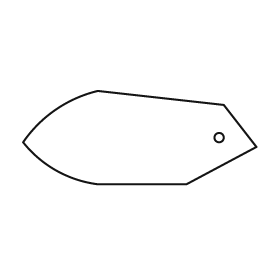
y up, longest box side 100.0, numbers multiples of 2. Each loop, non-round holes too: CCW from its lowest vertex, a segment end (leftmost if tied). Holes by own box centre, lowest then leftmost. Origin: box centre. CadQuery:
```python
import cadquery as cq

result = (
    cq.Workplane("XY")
    .moveTo(-18.0, -20.0)
    .lineTo(20.0, -20.0)
    .lineTo(50.0, -4.0)
    .lineTo(36.0, 14.0)
    .lineTo(-18.0, 20.0)
    .threePointArc((-36.0, 12.0), (-50.0, -2.0))
    .threePointArc((-36.0, -14.0), (-18.0, -20.0))
    .close()
    .moveTo(34.0, 0.0)
    .circle(2.0)
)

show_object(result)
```